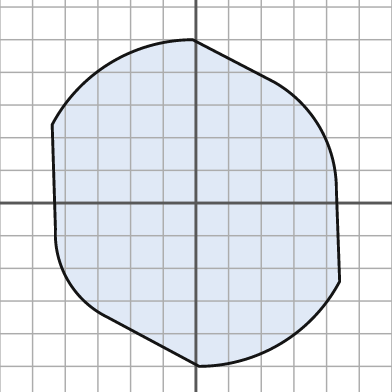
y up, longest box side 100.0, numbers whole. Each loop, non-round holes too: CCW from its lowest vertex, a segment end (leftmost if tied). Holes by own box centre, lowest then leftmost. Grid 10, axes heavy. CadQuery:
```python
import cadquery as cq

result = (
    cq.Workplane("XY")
    .moveTo(1.0, -50.0)
    .threePointArc((26.0, -43.0), (44.0, -24.0))
    .lineTo(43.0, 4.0)
    .threePointArc((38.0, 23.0), (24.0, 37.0))
    .lineTo(-1.0, 50.0)
    .threePointArc((-26.0, 43.0), (-44.0, 24.0))
    .lineTo(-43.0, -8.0)
    .threePointArc((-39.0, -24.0), (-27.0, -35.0))
    .close()
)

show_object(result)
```